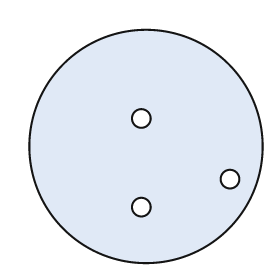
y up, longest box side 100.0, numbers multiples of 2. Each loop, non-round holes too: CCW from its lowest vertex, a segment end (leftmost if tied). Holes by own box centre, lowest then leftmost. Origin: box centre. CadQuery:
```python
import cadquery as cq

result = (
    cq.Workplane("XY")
    .moveTo(0.0, 0.0)
    .circle(50.0)
    .moveTo(-2.0, -26.0)
    .circle(4.0)
    .moveTo(36.0, -14.0)
    .circle(4.0)
    .moveTo(-2.0, 12.0)
    .circle(4.0)
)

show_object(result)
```